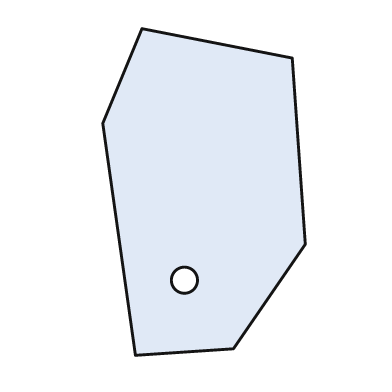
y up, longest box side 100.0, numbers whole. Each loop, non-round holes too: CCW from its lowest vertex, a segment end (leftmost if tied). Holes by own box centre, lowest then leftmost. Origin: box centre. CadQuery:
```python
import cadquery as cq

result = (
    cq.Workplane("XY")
    .moveTo(-21.0, -50.0)
    .lineTo(9.0, -48.0)
    .lineTo(31.0, -16.0)
    .lineTo(27.0, 41.0)
    .lineTo(-19.0, 50.0)
    .lineTo(-31.0, 21.0)
    .close()
    .moveTo(-6.0, -27.0)
    .circle(4.0)
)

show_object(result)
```